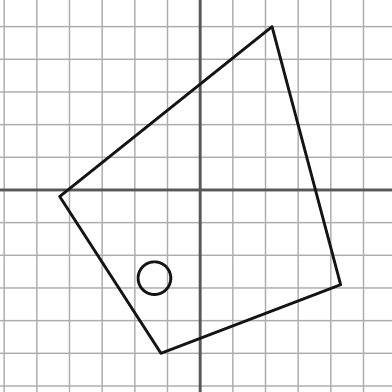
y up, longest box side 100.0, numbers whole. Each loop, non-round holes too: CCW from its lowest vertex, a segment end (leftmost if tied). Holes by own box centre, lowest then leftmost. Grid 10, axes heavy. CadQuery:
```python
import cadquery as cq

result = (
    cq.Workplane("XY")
    .moveTo(-12.0, -50.0)
    .lineTo(43.0, -29.0)
    .lineTo(22.0, 50.0)
    .lineTo(-43.0, -2.0)
    .close()
    .moveTo(-14.0, -27.0)
    .circle(5.0)
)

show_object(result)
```